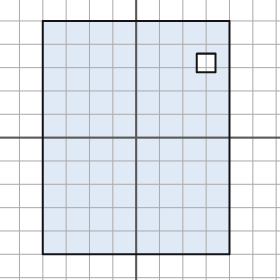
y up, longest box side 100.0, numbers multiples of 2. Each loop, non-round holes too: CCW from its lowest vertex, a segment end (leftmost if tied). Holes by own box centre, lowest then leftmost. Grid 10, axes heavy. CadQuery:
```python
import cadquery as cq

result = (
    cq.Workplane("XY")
    .moveTo(-40.0, -50.0)
    .lineTo(40.0, -50.0)
    .lineTo(40.0, 50.0)
    .lineTo(-40.0, 50.0)
    .close()
    .moveTo(26.0, 28.0)
    .lineTo(34.0, 28.0)
    .lineTo(34.0, 36.0)
    .lineTo(26.0, 36.0)
    .close()
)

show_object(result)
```